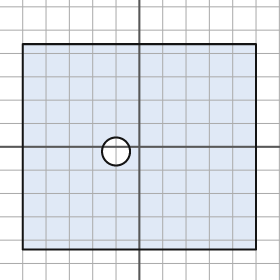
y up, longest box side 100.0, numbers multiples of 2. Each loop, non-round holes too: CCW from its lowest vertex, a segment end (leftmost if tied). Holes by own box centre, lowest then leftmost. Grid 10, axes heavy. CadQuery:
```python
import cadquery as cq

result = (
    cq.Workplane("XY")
    .moveTo(-50.0, -44.0)
    .lineTo(50.0, -44.0)
    .lineTo(50.0, 44.0)
    .lineTo(-50.0, 44.0)
    .close()
    .moveTo(-10.0, -2.0)
    .circle(6.0)
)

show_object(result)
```